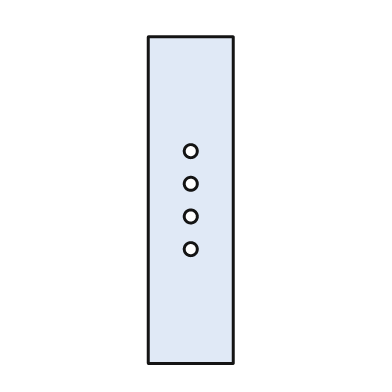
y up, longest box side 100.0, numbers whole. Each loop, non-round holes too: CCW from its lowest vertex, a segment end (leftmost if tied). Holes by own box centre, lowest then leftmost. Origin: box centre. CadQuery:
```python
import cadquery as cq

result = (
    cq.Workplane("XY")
    .moveTo(-13.0, -50.0)
    .lineTo(13.0, -50.0)
    .lineTo(13.0, 50.0)
    .lineTo(-13.0, 50.0)
    .close()
    .moveTo(0.0, -15.0)
    .circle(2.0)
    .moveTo(0.0, -5.0)
    .circle(2.0)
    .moveTo(0.0, 5.0)
    .circle(2.0)
    .moveTo(0.0, 15.0)
    .circle(2.0)
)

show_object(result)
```